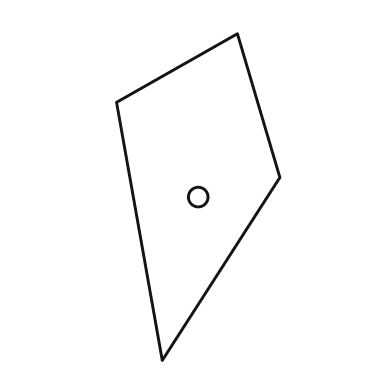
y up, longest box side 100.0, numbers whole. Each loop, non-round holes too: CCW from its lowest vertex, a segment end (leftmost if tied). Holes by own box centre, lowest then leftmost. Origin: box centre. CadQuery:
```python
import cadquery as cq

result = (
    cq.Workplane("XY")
    .moveTo(-11.0, -50.0)
    .lineTo(25.0, 6.0)
    .lineTo(12.0, 50.0)
    .lineTo(-25.0, 29.0)
    .close()
    .moveTo(0.0, 0.0)
    .circle(3.0)
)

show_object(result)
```